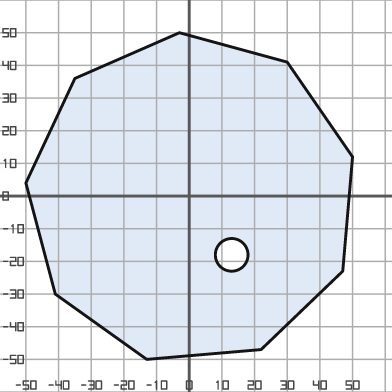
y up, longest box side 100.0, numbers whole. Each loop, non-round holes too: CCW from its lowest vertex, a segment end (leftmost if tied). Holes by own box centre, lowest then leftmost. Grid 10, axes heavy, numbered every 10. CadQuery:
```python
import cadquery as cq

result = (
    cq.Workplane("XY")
    .moveTo(-13.0, -50.0)
    .lineTo(22.0, -47.0)
    .lineTo(47.0, -23.0)
    .lineTo(50.0, 12.0)
    .lineTo(30.0, 41.0)
    .lineTo(-3.0, 50.0)
    .lineTo(-35.0, 36.0)
    .lineTo(-50.0, 4.0)
    .lineTo(-41.0, -30.0)
    .close()
    .moveTo(13.0, -18.0)
    .circle(5.0)
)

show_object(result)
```